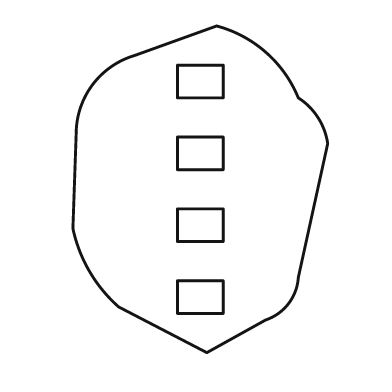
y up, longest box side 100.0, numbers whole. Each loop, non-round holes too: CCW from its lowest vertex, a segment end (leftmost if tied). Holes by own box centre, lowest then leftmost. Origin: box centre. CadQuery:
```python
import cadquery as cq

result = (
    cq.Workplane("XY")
    .moveTo(2.0, -50.0)
    .lineTo(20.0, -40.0)
    .threePointArc((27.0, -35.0), (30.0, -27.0))
    .lineTo(39.0, 14.0)
    .threePointArc((36.0, 22.0), (30.0, 28.0))
    .threePointArc((20.0, 42.0), (5.0, 50.0))
    .lineTo(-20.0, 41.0)
    .threePointArc((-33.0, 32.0), (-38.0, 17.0))
    .lineTo(-39.0, -12.0)
    .threePointArc((-34.0, -25.0), (-25.0, -36.0))
    .close()
    .moveTo(-7.0, -38.0)
    .lineTo(7.0, -38.0)
    .lineTo(7.0, -28.0)
    .lineTo(-7.0, -28.0)
    .close()
    .moveTo(-7.0, -16.0)
    .lineTo(7.0, -16.0)
    .lineTo(7.0, -6.0)
    .lineTo(-7.0, -6.0)
    .close()
    .moveTo(-7.0, 6.0)
    .lineTo(7.0, 6.0)
    .lineTo(7.0, 16.0)
    .lineTo(-7.0, 16.0)
    .close()
    .moveTo(-7.0, 28.0)
    .lineTo(7.0, 28.0)
    .lineTo(7.0, 38.0)
    .lineTo(-7.0, 38.0)
    .close()
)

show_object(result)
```